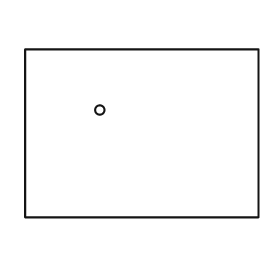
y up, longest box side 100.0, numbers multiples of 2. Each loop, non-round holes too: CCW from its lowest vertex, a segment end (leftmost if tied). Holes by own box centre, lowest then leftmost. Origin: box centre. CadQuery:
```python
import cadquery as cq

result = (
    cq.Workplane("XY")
    .moveTo(-50.0, -36.0)
    .lineTo(50.0, -36.0)
    .lineTo(50.0, 36.0)
    .lineTo(-50.0, 36.0)
    .close()
    .moveTo(-18.0, 10.0)
    .circle(2.0)
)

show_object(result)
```